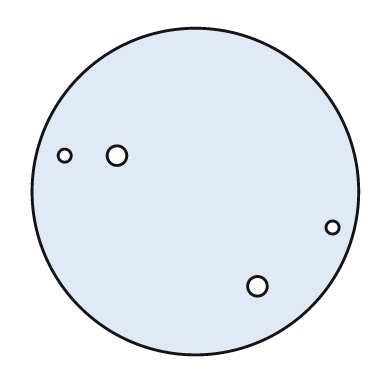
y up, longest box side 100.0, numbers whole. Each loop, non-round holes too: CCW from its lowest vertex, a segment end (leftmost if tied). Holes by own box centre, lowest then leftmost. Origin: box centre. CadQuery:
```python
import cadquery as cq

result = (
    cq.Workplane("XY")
    .moveTo(0.0, 0.0)
    .circle(50.0)
    .moveTo(19.0, -29.0)
    .circle(3.0)
    .moveTo(42.0, -11.0)
    .circle(2.0)
    .moveTo(-40.0, 11.0)
    .circle(2.0)
    .moveTo(-24.0, 11.0)
    .circle(3.0)
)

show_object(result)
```